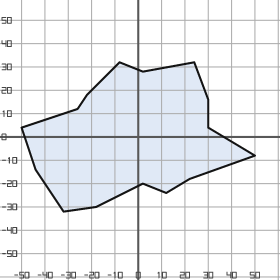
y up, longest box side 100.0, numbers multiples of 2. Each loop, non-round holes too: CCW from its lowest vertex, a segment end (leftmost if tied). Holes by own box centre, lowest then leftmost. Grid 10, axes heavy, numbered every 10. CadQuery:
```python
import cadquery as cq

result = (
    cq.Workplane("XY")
    .moveTo(-32.0, -32.0)
    .lineTo(-18.0, -30.0)
    .lineTo(2.0, -20.0)
    .lineTo(12.0, -24.0)
    .lineTo(22.0, -18.0)
    .lineTo(50.0, -8.0)
    .lineTo(30.0, 4.0)
    .lineTo(30.0, 16.0)
    .lineTo(24.0, 32.0)
    .lineTo(2.0, 28.0)
    .lineTo(-8.0, 32.0)
    .lineTo(-22.0, 18.0)
    .lineTo(-26.0, 12.0)
    .lineTo(-50.0, 4.0)
    .lineTo(-44.0, -14.0)
    .close()
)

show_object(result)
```